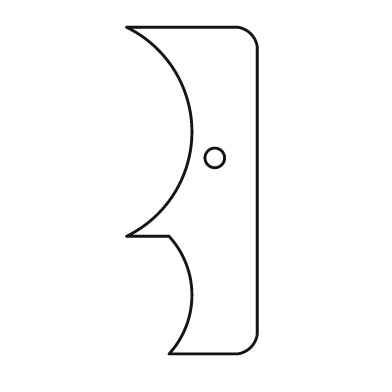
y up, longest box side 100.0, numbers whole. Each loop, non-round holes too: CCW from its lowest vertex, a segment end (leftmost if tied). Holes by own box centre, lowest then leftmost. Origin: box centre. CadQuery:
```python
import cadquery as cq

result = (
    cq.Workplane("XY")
    .moveTo(-7.0, -50.0)
    .lineTo(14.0, -50.0)
    .threePointArc((18.0, -48.0), (20.0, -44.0))
    .lineTo(20.0, 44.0)
    .threePointArc((18.0, 48.0), (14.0, 50.0))
    .lineTo(-20.0, 50.0)
    .threePointArc((0.0, 18.0), (-20.0, -14.0))
    .lineTo(-7.0, -14.0)
    .threePointArc((0.0, -32.0), (-7.0, -50.0))
    .close()
    .moveTo(7.0, 10.0)
    .circle(3.0)
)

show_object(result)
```